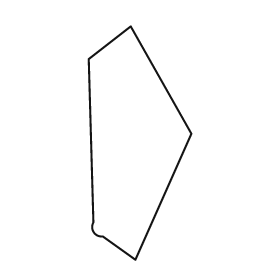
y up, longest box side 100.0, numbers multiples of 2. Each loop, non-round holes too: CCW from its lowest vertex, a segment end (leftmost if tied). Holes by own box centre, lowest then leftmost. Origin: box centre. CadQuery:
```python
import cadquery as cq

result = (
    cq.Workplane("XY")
    .moveTo(-2.0, -50.0)
    .lineTo(22.0, 4.0)
    .lineTo(-4.0, 50.0)
    .lineTo(-22.0, 36.0)
    .lineTo(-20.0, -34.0)
    .threePointArc((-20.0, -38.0), (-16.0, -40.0))
    .close()
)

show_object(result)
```